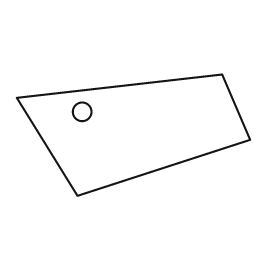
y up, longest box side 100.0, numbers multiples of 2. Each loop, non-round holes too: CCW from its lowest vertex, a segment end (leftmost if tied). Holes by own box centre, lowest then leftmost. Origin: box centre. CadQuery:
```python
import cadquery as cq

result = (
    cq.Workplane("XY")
    .moveTo(-24.0, -26.0)
    .lineTo(50.0, -2.0)
    .lineTo(38.0, 26.0)
    .lineTo(-50.0, 16.0)
    .close()
    .moveTo(-22.0, 10.0)
    .circle(4.0)
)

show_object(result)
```